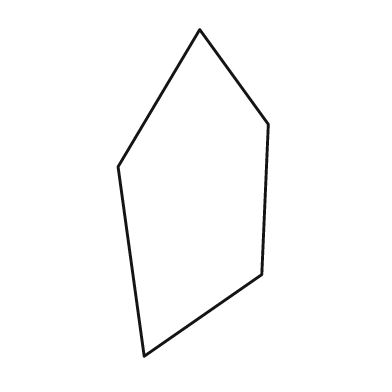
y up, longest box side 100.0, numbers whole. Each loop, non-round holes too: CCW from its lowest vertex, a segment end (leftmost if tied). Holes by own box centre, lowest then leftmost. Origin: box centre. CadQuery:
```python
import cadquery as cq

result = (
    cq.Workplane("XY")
    .moveTo(-15.0, -50.0)
    .lineTo(21.0, -25.0)
    .lineTo(23.0, 21.0)
    .lineTo(2.0, 50.0)
    .lineTo(-23.0, 8.0)
    .close()
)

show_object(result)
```